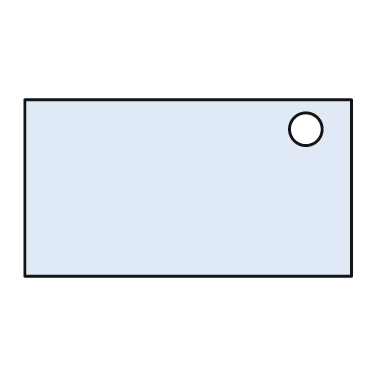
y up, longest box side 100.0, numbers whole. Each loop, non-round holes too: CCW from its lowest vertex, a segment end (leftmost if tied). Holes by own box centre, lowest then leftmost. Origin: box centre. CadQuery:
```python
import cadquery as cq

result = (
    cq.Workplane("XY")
    .moveTo(-50.0, -27.0)
    .lineTo(50.0, -27.0)
    .lineTo(50.0, 27.0)
    .lineTo(-50.0, 27.0)
    .close()
    .moveTo(36.0, 18.0)
    .circle(5.0)
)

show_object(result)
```